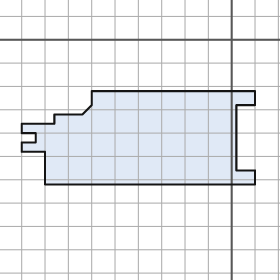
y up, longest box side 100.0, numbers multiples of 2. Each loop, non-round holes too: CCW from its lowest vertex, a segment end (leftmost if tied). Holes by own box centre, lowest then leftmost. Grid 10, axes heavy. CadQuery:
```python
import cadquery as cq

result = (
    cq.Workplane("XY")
    .moveTo(-80.0, -62.0)
    .lineTo(10.0, -62.0)
    .lineTo(10.0, -56.0)
    .lineTo(2.0, -56.0)
    .lineTo(2.0, -28.0)
    .lineTo(10.0, -28.0)
    .lineTo(10.0, -22.0)
    .lineTo(-60.0, -22.0)
    .lineTo(-60.0, -28.0)
    .lineTo(-64.0, -32.0)
    .lineTo(-76.0, -32.0)
    .lineTo(-76.0, -36.0)
    .lineTo(-90.0, -36.0)
    .lineTo(-90.0, -40.0)
    .lineTo(-84.0, -40.0)
    .lineTo(-84.0, -44.0)
    .lineTo(-90.0, -44.0)
    .lineTo(-90.0, -48.0)
    .lineTo(-80.0, -48.0)
    .close()
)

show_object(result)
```